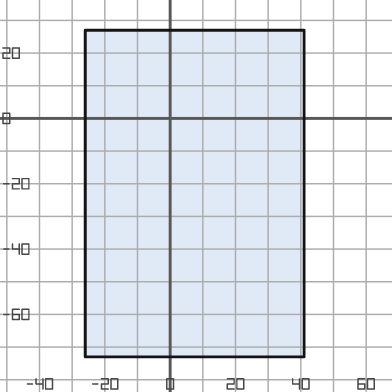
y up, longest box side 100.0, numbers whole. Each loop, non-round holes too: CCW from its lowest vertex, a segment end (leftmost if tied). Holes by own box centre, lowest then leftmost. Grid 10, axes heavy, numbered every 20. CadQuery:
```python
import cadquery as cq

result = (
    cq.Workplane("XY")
    .moveTo(-26.0, -73.0)
    .lineTo(41.0, -73.0)
    .lineTo(41.0, 27.0)
    .lineTo(-26.0, 27.0)
    .close()
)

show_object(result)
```